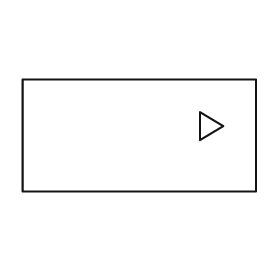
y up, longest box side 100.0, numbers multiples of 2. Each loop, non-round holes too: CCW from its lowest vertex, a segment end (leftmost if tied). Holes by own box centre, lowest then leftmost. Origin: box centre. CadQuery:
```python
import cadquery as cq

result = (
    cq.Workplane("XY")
    .moveTo(-50.0, -24.0)
    .lineTo(50.0, -24.0)
    .lineTo(50.0, 24.0)
    .lineTo(-50.0, 24.0)
    .close()
    .moveTo(26.0, -2.0)
    .lineTo(36.0, 4.0)
    .lineTo(26.0, 10.0)
    .close()
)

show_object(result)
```